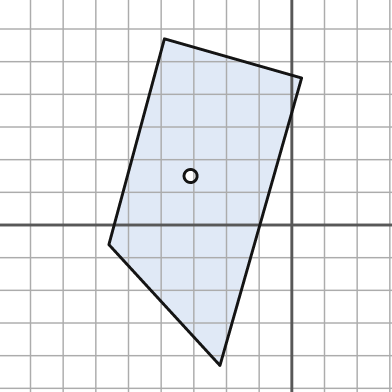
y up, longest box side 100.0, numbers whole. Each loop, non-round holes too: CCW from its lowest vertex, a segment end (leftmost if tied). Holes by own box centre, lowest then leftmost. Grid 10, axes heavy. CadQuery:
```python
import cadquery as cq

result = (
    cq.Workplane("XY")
    .moveTo(-22.0, -43.0)
    .lineTo(3.0, 45.0)
    .lineTo(-39.0, 57.0)
    .lineTo(-56.0, -6.0)
    .close()
    .moveTo(-31.0, 15.0)
    .circle(2.0)
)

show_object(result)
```